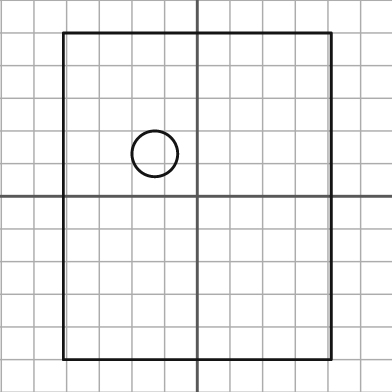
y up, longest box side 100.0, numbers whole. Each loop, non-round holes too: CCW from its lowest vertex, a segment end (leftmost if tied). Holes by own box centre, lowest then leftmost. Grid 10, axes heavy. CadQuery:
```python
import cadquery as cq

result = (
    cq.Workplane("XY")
    .moveTo(-41.0, -50.0)
    .lineTo(41.0, -50.0)
    .lineTo(41.0, 50.0)
    .lineTo(-41.0, 50.0)
    .close()
    .moveTo(-13.0, 13.0)
    .circle(7.0)
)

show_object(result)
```